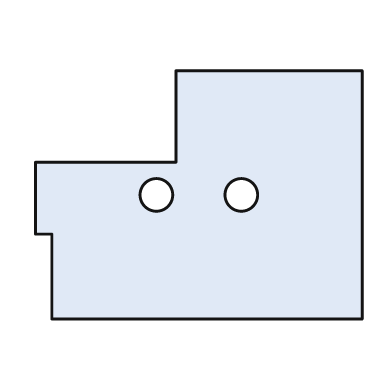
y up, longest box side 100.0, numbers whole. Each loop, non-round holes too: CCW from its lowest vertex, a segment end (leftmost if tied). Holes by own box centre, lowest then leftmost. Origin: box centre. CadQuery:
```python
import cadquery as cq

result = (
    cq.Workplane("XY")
    .moveTo(-45.0, -38.0)
    .lineTo(50.0, -38.0)
    .lineTo(50.0, 38.0)
    .lineTo(-7.0, 38.0)
    .lineTo(-7.0, 10.0)
    .lineTo(-50.0, 10.0)
    .lineTo(-50.0, -12.0)
    .lineTo(-45.0, -12.0)
    .close()
    .moveTo(-13.0, 0.0)
    .circle(5.0)
    .moveTo(13.0, 0.0)
    .circle(5.0)
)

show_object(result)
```